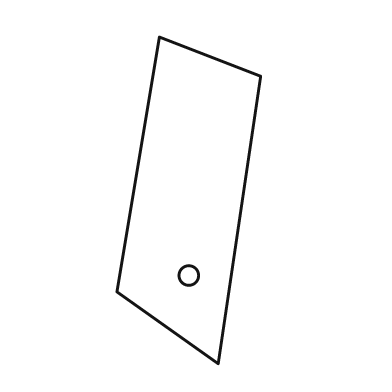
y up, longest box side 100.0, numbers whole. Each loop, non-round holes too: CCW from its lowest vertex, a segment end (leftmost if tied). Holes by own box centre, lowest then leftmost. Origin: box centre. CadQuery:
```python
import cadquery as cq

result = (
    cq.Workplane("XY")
    .moveTo(9.0, -50.0)
    .lineTo(22.0, 38.0)
    .lineTo(-9.0, 50.0)
    .lineTo(-22.0, -28.0)
    .close()
    .moveTo(0.0, -23.0)
    .circle(3.0)
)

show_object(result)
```